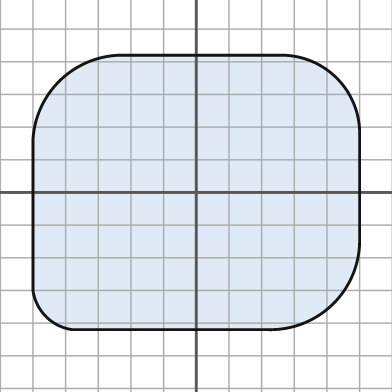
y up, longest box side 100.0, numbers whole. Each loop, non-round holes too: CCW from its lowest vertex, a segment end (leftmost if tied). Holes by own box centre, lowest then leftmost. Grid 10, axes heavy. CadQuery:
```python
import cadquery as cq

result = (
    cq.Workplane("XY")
    .moveTo(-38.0, -42.0)
    .lineTo(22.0, -42.0)
    .threePointArc((42.0, -34.0), (50.0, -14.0))
    .lineTo(50.0, 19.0)
    .threePointArc((43.0, 35.0), (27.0, 42.0))
    .lineTo(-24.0, 42.0)
    .threePointArc((-42.0, 34.0), (-50.0, 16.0))
    .lineTo(-50.0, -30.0)
    .threePointArc((-46.0, -38.0), (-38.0, -42.0))
    .close()
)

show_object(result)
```